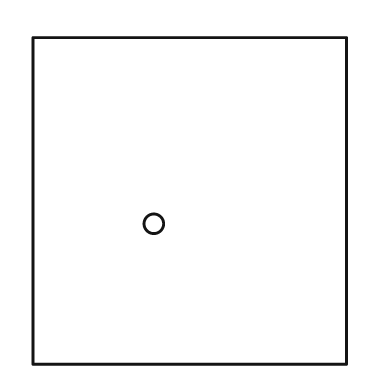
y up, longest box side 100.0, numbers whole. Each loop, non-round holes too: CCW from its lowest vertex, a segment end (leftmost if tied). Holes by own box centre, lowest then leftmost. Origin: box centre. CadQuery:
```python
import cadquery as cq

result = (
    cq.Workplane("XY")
    .moveTo(-48.0, -50.0)
    .lineTo(48.0, -50.0)
    .lineTo(48.0, 50.0)
    .lineTo(-48.0, 50.0)
    .close()
    .moveTo(-11.0, -7.0)
    .circle(3.0)
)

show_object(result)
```